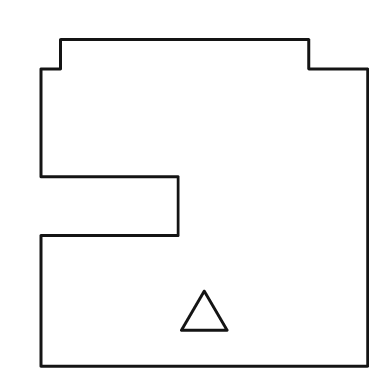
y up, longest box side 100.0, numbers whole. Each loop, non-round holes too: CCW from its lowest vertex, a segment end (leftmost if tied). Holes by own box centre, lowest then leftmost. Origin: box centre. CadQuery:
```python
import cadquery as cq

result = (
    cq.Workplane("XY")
    .moveTo(-50.0, -50.0)
    .lineTo(50.0, -50.0)
    .lineTo(50.0, 41.0)
    .lineTo(32.0, 41.0)
    .lineTo(32.0, 50.0)
    .lineTo(-44.0, 50.0)
    .lineTo(-44.0, 41.0)
    .lineTo(-50.0, 41.0)
    .lineTo(-50.0, 8.0)
    .lineTo(-8.0, 8.0)
    .lineTo(-8.0, -10.0)
    .lineTo(-50.0, -10.0)
    .close()
    .moveTo(-7.0, -39.0)
    .lineTo(7.0, -39.0)
    .lineTo(0.0, -27.0)
    .close()
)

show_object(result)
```